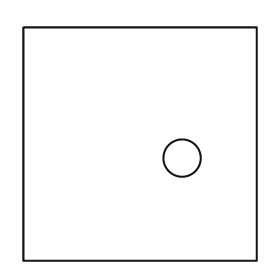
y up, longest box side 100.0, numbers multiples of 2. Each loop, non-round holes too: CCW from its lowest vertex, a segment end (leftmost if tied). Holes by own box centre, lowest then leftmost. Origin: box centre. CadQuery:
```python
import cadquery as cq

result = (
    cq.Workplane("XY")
    .moveTo(-50.0, -50.0)
    .lineTo(50.0, -50.0)
    .lineTo(50.0, 50.0)
    .lineTo(-50.0, 50.0)
    .close()
    .moveTo(18.0, -6.0)
    .circle(8.0)
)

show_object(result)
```